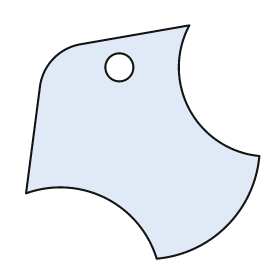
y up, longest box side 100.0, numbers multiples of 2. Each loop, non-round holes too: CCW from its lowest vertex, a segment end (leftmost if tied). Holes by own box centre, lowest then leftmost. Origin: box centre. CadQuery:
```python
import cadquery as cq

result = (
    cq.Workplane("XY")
    .moveTo(6.0, -50.0)
    .threePointArc((36.0, -36.0), (50.0, -6.0))
    .threePointArc((20.0, 14.0), (20.0, 50.0))
    .lineTo(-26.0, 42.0)
    .threePointArc((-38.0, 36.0), (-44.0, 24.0))
    .lineTo(-50.0, -22.0)
    .threePointArc((-16.0, -24.0), (6.0, -50.0))
    .close()
    .moveTo(-10.0, 32.0)
    .circle(6.0)
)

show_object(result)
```